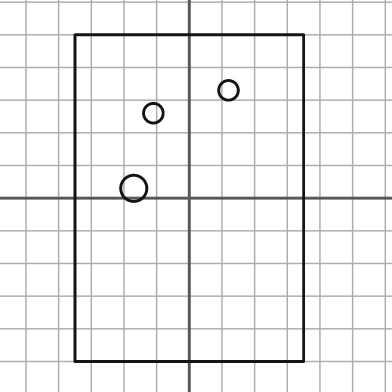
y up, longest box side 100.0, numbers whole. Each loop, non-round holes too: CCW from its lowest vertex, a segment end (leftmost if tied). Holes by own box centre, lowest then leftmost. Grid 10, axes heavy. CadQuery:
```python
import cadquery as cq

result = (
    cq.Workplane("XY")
    .moveTo(-35.0, -50.0)
    .lineTo(35.0, -50.0)
    .lineTo(35.0, 50.0)
    .lineTo(-35.0, 50.0)
    .close()
    .moveTo(-17.0, 3.0)
    .circle(4.0)
    .moveTo(-11.0, 26.0)
    .circle(3.0)
    .moveTo(12.0, 33.0)
    .circle(3.0)
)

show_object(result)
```